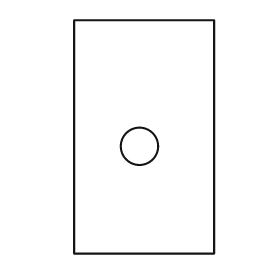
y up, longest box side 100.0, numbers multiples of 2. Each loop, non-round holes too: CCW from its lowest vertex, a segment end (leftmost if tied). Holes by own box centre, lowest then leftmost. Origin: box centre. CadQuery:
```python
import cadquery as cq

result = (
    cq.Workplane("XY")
    .moveTo(-30.0, -50.0)
    .lineTo(30.0, -50.0)
    .lineTo(30.0, 50.0)
    .lineTo(-30.0, 50.0)
    .close()
    .moveTo(-2.0, -4.0)
    .circle(8.0)
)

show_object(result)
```